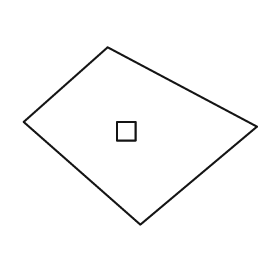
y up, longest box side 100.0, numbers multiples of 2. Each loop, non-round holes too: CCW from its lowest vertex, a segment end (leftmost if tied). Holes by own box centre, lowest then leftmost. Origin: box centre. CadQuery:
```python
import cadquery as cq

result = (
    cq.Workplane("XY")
    .moveTo(0.0, -38.0)
    .lineTo(50.0, 4.0)
    .lineTo(-14.0, 38.0)
    .lineTo(-50.0, 6.0)
    .close()
    .moveTo(-10.0, -2.0)
    .lineTo(-2.0, -2.0)
    .lineTo(-2.0, 6.0)
    .lineTo(-10.0, 6.0)
    .close()
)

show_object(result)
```